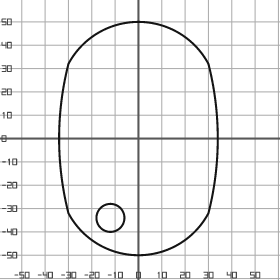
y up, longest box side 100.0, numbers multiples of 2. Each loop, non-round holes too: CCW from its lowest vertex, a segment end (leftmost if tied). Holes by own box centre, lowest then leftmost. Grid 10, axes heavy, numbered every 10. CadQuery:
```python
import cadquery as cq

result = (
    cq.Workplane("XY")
    .moveTo(-30.0, -32.0)
    .threePointArc((0.0, -50.0), (30.0, -32.0))
    .threePointArc((34.0, 0.0), (30.0, 32.0))
    .threePointArc((0.0, 50.0), (-30.0, 32.0))
    .threePointArc((-34.0, 0.0), (-30.0, -32.0))
    .close()
    .moveTo(-12.0, -34.0)
    .circle(6.0)
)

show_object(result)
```